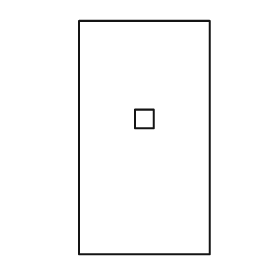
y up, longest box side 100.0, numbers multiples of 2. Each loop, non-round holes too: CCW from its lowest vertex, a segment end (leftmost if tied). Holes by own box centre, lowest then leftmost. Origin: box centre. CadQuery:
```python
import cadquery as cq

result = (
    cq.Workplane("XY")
    .moveTo(-28.0, -50.0)
    .lineTo(28.0, -50.0)
    .lineTo(28.0, 50.0)
    .lineTo(-28.0, 50.0)
    .close()
    .moveTo(-4.0, 4.0)
    .lineTo(4.0, 4.0)
    .lineTo(4.0, 12.0)
    .lineTo(-4.0, 12.0)
    .close()
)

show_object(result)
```